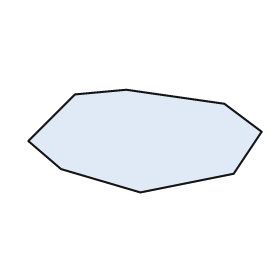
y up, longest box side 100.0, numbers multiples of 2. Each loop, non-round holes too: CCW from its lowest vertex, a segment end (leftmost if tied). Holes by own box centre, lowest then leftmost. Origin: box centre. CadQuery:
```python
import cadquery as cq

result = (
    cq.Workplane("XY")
    .moveTo(-2.0, -22.0)
    .lineTo(38.0, -14.0)
    .lineTo(50.0, 4.0)
    .lineTo(34.0, 16.0)
    .lineTo(-8.0, 22.0)
    .lineTo(-30.0, 20.0)
    .lineTo(-50.0, 0.0)
    .lineTo(-36.0, -12.0)
    .close()
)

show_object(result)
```